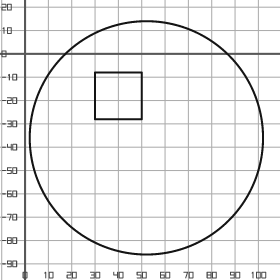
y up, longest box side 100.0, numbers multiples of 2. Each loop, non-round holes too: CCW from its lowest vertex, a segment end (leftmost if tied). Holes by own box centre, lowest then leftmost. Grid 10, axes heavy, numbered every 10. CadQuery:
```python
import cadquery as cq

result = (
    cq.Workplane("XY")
    .moveTo(52.0, -36.0)
    .circle(50.0)
    .moveTo(30.0, -28.0)
    .lineTo(50.0, -28.0)
    .lineTo(50.0, -8.0)
    .lineTo(30.0, -8.0)
    .close()
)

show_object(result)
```